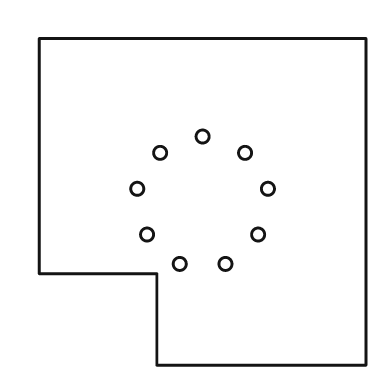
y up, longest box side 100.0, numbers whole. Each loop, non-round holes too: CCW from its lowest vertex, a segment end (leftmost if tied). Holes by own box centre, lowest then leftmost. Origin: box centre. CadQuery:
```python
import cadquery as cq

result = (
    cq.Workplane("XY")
    .moveTo(-14.0, -50.0)
    .lineTo(50.0, -50.0)
    .lineTo(50.0, 50.0)
    .lineTo(-50.0, 50.0)
    .lineTo(-50.0, -22.0)
    .lineTo(-14.0, -22.0)
    .close()
    .moveTo(-7.0, -19.0)
    .circle(2.0)
    .moveTo(7.0, -19.0)
    .circle(2.0)
    .moveTo(-17.0, -10.0)
    .circle(2.0)
    .moveTo(17.0, -10.0)
    .circle(2.0)
    .moveTo(-20.0, 4.0)
    .circle(2.0)
    .moveTo(20.0, 4.0)
    .circle(2.0)
    .moveTo(-13.0, 15.0)
    .circle(2.0)
    .moveTo(13.0, 15.0)
    .circle(2.0)
    .moveTo(0.0, 20.0)
    .circle(2.0)
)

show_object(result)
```